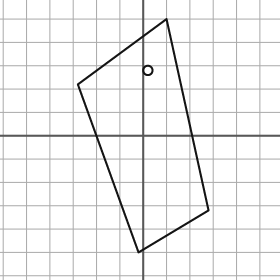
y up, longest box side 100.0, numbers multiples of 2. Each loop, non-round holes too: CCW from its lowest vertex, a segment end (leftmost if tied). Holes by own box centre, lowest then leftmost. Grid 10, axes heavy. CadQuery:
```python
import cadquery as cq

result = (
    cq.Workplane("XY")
    .moveTo(-2.0, -50.0)
    .lineTo(28.0, -32.0)
    .lineTo(10.0, 50.0)
    .lineTo(-28.0, 22.0)
    .close()
    .moveTo(2.0, 28.0)
    .circle(2.0)
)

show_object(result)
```